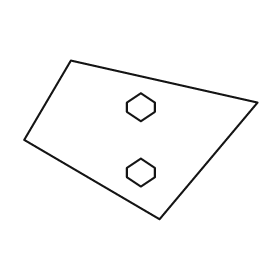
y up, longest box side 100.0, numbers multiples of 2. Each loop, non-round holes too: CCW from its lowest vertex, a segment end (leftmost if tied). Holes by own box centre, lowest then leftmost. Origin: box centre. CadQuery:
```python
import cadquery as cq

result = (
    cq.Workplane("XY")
    .moveTo(8.0, -34.0)
    .lineTo(50.0, 16.0)
    .lineTo(-30.0, 34.0)
    .lineTo(-50.0, 0.0)
    .close()
    .moveTo(0.0, -20.0)
    .lineTo(6.0, -16.0)
    .lineTo(6.0, -12.0)
    .lineTo(0.0, -8.0)
    .lineTo(-6.0, -12.0)
    .lineTo(-6.0, -16.0)
    .close()
    .moveTo(0.0, 8.0)
    .lineTo(6.0, 12.0)
    .lineTo(6.0, 16.0)
    .lineTo(0.0, 20.0)
    .lineTo(-6.0, 16.0)
    .lineTo(-6.0, 12.0)
    .close()
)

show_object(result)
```